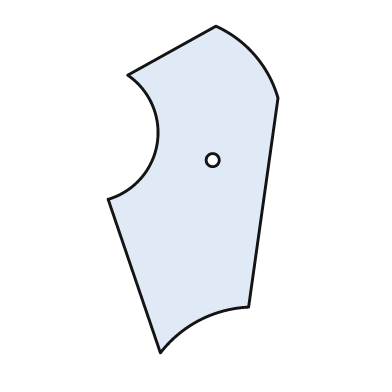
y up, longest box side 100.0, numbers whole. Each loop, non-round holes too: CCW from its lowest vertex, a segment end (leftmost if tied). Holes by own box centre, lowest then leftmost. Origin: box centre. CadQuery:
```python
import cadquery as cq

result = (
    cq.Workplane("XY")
    .moveTo(-10.0, -50.0)
    .threePointArc((2.0, -40.0), (17.0, -36.0))
    .lineTo(26.0, 28.0)
    .threePointArc((19.0, 41.0), (7.0, 50.0))
    .lineTo(-20.0, 35.0)
    .threePointArc((-11.0, 14.0), (-26.0, -3.0))
    .close()
    .moveTo(6.0, 9.0)
    .circle(2.0)
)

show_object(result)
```